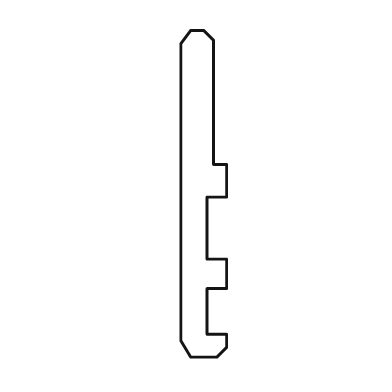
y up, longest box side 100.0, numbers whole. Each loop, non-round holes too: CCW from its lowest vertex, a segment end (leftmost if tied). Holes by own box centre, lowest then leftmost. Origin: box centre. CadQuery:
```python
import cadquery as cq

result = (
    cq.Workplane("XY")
    .moveTo(-4.0, -50.0)
    .lineTo(4.0, -50.0)
    .lineTo(7.0, -47.0)
    .lineTo(7.0, -43.0)
    .lineTo(1.0, -43.0)
    .lineTo(1.0, -29.0)
    .lineTo(7.0, -29.0)
    .lineTo(7.0, -20.0)
    .lineTo(1.0, -20.0)
    .lineTo(1.0, -1.0)
    .lineTo(7.0, -1.0)
    .lineTo(7.0, 9.0)
    .lineTo(3.0, 9.0)
    .lineTo(3.0, 47.0)
    .lineTo(0.0, 50.0)
    .lineTo(-4.0, 50.0)
    .lineTo(-7.0, 46.0)
    .lineTo(-7.0, -45.0)
    .close()
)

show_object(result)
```